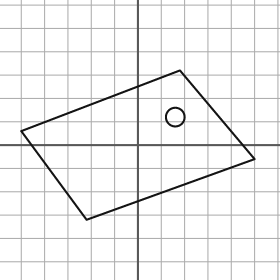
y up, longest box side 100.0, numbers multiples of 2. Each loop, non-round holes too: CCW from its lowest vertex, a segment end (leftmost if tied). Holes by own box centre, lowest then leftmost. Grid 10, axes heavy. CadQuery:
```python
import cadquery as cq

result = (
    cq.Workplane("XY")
    .moveTo(-22.0, -32.0)
    .lineTo(50.0, -6.0)
    .lineTo(18.0, 32.0)
    .lineTo(-50.0, 6.0)
    .close()
    .moveTo(16.0, 12.0)
    .circle(4.0)
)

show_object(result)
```